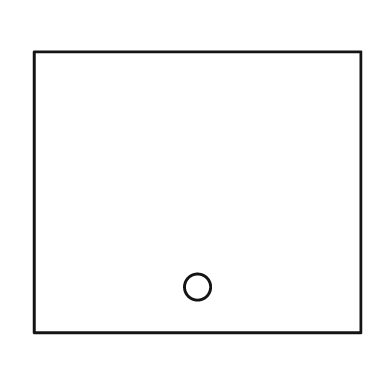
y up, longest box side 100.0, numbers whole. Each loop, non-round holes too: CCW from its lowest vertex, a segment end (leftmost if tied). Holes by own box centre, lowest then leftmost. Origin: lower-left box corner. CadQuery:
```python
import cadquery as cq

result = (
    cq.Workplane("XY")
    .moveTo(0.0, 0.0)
    .lineTo(100.0, 0.0)
    .lineTo(100.0, 86.0)
    .lineTo(0.0, 86.0)
    .close()
    .moveTo(50.0, 14.0)
    .circle(4.0)
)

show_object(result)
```